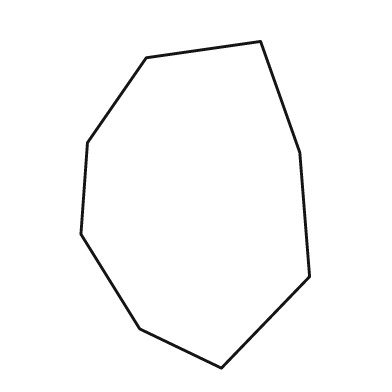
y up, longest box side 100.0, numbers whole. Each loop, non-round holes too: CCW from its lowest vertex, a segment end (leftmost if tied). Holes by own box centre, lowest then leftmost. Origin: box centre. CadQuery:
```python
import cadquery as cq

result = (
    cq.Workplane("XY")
    .moveTo(8.0, -50.0)
    .lineTo(35.0, -22.0)
    .lineTo(32.0, 16.0)
    .lineTo(20.0, 50.0)
    .lineTo(-15.0, 45.0)
    .lineTo(-33.0, 19.0)
    .lineTo(-35.0, -9.0)
    .lineTo(-17.0, -38.0)
    .close()
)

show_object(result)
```